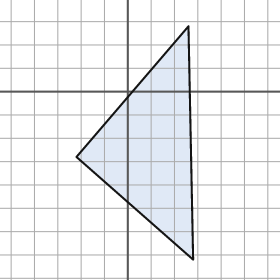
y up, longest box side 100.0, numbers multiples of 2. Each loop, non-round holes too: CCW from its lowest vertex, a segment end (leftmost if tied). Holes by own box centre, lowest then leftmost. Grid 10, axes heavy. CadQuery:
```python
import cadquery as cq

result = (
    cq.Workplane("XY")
    .moveTo(28.0, -72.0)
    .lineTo(26.0, 28.0)
    .lineTo(-22.0, -28.0)
    .close()
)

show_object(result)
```